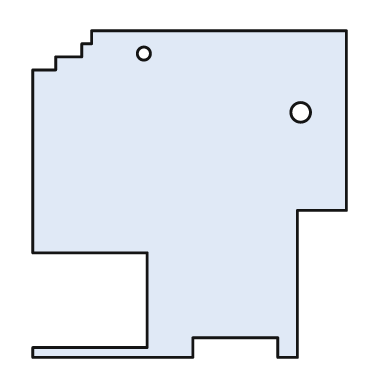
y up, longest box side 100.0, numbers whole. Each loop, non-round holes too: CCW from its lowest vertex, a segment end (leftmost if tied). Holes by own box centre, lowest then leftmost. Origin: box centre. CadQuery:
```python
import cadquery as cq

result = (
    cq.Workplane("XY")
    .moveTo(-48.0, -50.0)
    .lineTo(1.0, -50.0)
    .lineTo(1.0, -44.0)
    .lineTo(27.0, -44.0)
    .lineTo(27.0, -50.0)
    .lineTo(33.0, -50.0)
    .lineTo(33.0, -5.0)
    .lineTo(48.0, -5.0)
    .lineTo(48.0, 50.0)
    .lineTo(-30.0, 50.0)
    .lineTo(-30.0, 46.0)
    .lineTo(-33.0, 46.0)
    .lineTo(-33.0, 42.0)
    .lineTo(-41.0, 42.0)
    .lineTo(-41.0, 38.0)
    .lineTo(-48.0, 38.0)
    .lineTo(-48.0, -18.0)
    .lineTo(-13.0, -18.0)
    .lineTo(-13.0, -47.0)
    .lineTo(-48.0, -47.0)
    .close()
    .moveTo(34.0, 25.0)
    .circle(3.0)
    .moveTo(-14.0, 43.0)
    .circle(2.0)
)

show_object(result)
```